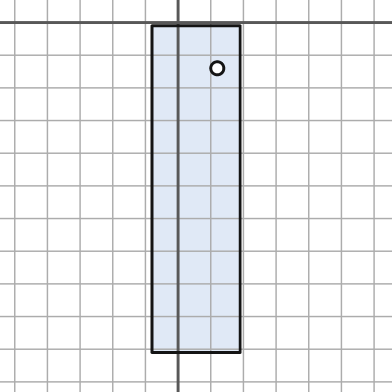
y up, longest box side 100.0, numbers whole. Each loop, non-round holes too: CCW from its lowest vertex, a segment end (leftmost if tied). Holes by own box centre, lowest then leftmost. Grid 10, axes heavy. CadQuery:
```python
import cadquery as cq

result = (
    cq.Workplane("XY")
    .moveTo(-8.0, -101.0)
    .lineTo(19.0, -101.0)
    .lineTo(19.0, -1.0)
    .lineTo(-8.0, -1.0)
    .close()
    .moveTo(12.0, -14.0)
    .circle(2.0)
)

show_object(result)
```